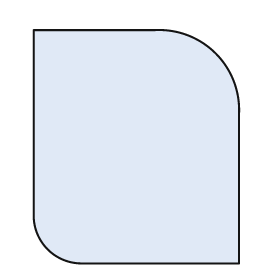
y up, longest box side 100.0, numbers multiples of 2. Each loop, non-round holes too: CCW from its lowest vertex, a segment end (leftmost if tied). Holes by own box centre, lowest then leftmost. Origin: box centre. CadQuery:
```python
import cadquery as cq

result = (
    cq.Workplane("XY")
    .moveTo(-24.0, -50.0)
    .lineTo(44.0, -50.0)
    .lineTo(44.0, 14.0)
    .threePointArc((34.0, 40.0), (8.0, 50.0))
    .lineTo(-44.0, 50.0)
    .lineTo(-44.0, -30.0)
    .threePointArc((-38.0, -44.0), (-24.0, -50.0))
    .close()
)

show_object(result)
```